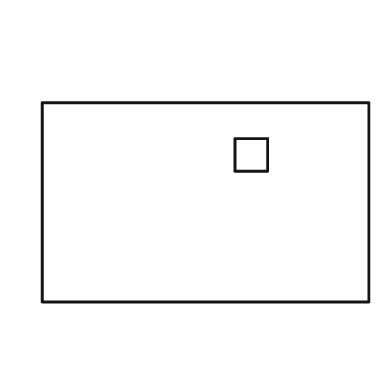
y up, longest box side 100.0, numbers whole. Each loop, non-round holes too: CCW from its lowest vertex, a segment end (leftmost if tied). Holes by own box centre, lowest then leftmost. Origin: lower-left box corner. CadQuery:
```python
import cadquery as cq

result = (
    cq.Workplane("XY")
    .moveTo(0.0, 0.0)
    .lineTo(100.0, 0.0)
    .lineTo(100.0, 61.0)
    .lineTo(0.0, 61.0)
    .close()
    .moveTo(59.0, 40.0)
    .lineTo(69.0, 40.0)
    .lineTo(69.0, 50.0)
    .lineTo(59.0, 50.0)
    .close()
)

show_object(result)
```